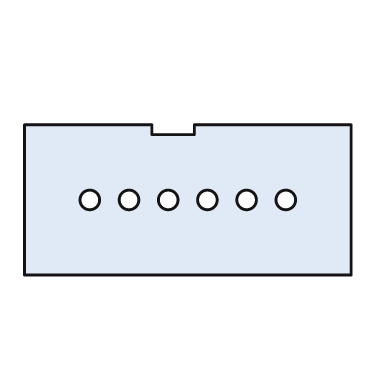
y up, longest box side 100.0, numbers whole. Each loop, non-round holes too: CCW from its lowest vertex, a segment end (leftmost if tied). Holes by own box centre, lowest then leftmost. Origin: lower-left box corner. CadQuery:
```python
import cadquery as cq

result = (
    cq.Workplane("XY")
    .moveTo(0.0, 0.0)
    .lineTo(100.0, 0.0)
    .lineTo(100.0, 46.0)
    .lineTo(52.0, 46.0)
    .lineTo(52.0, 43.0)
    .lineTo(39.0, 43.0)
    .lineTo(39.0, 46.0)
    .lineTo(0.0, 46.0)
    .close()
    .moveTo(20.0, 23.0)
    .circle(3.0)
    .moveTo(32.0, 23.0)
    .circle(3.0)
    .moveTo(44.0, 23.0)
    .circle(3.0)
    .moveTo(56.0, 23.0)
    .circle(3.0)
    .moveTo(68.0, 23.0)
    .circle(3.0)
    .moveTo(80.0, 23.0)
    .circle(3.0)
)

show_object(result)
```